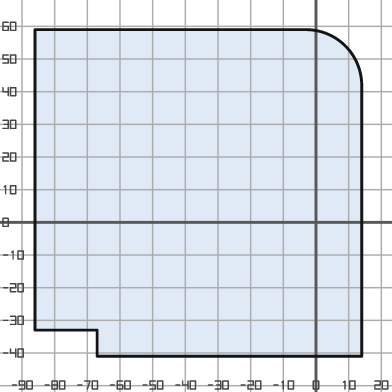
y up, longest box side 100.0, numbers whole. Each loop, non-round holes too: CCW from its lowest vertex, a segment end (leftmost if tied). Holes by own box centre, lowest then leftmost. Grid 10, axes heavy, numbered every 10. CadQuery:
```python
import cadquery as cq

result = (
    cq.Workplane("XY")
    .moveTo(-67.0, -41.0)
    .lineTo(14.0, -41.0)
    .lineTo(14.0, 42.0)
    .threePointArc((9.0, 54.0), (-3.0, 59.0))
    .lineTo(-86.0, 59.0)
    .lineTo(-86.0, -33.0)
    .lineTo(-67.0, -33.0)
    .close()
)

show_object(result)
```